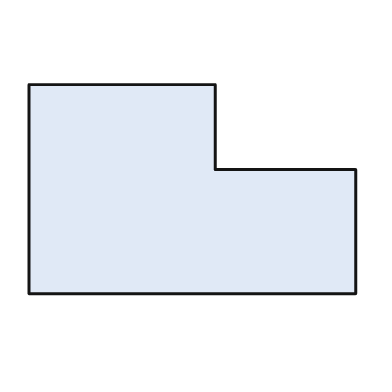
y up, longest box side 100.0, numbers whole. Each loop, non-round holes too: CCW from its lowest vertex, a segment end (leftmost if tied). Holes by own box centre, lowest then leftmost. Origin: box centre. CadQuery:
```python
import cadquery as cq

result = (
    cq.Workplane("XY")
    .moveTo(-50.0, -32.0)
    .lineTo(50.0, -32.0)
    .lineTo(50.0, 6.0)
    .lineTo(7.0, 6.0)
    .lineTo(7.0, 32.0)
    .lineTo(-50.0, 32.0)
    .close()
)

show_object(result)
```